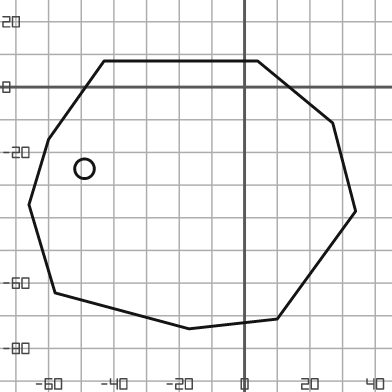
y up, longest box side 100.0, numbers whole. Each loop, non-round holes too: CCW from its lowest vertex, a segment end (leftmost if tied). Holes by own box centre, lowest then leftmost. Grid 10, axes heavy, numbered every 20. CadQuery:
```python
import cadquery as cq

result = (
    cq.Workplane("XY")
    .moveTo(-17.0, -74.0)
    .lineTo(10.0, -71.0)
    .lineTo(34.0, -38.0)
    .lineTo(27.0, -11.0)
    .lineTo(4.0, 8.0)
    .lineTo(-43.0, 8.0)
    .lineTo(-60.0, -16.0)
    .lineTo(-66.0, -36.0)
    .lineTo(-58.0, -63.0)
    .close()
    .moveTo(-49.0, -25.0)
    .circle(3.0)
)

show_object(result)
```